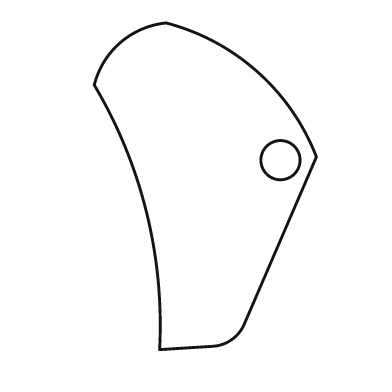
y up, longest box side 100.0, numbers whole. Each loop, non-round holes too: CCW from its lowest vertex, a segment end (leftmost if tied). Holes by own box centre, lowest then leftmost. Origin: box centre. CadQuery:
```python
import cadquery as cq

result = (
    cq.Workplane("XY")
    .moveTo(-14.0, -50.0)
    .lineTo(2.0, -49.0)
    .threePointArc((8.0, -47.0), (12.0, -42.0))
    .lineTo(34.0, 9.0)
    .threePointArc((16.0, 35.0), (-12.0, 50.0))
    .threePointArc((-26.0, 44.0), (-34.0, 31.0))
    .threePointArc((-18.0, -8.0), (-14.0, -50.0))
    .close()
    .moveTo(23.0, 8.0)
    .circle(6.0)
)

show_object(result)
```